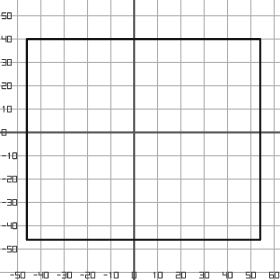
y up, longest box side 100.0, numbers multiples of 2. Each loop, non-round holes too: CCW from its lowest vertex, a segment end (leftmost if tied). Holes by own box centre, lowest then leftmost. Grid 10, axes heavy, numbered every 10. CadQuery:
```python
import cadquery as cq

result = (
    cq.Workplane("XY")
    .moveTo(-46.0, -46.0)
    .lineTo(54.0, -46.0)
    .lineTo(54.0, 40.0)
    .lineTo(-46.0, 40.0)
    .close()
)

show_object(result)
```